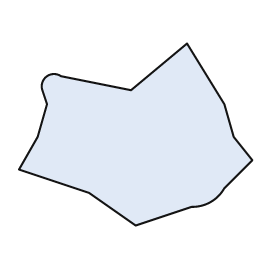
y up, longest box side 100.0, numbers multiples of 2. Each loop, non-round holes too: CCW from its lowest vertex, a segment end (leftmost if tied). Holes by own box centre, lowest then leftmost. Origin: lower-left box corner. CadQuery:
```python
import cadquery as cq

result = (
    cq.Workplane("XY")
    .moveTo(50.0, 0.0)
    .lineTo(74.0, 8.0)
    .threePointArc((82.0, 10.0), (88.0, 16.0))
    .lineTo(100.0, 28.0)
    .lineTo(92.0, 38.0)
    .lineTo(88.0, 52.0)
    .lineTo(72.0, 78.0)
    .lineTo(48.0, 58.0)
    .lineTo(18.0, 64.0)
    .threePointArc((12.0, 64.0), (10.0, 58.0))
    .lineTo(12.0, 52.0)
    .lineTo(8.0, 38.0)
    .lineTo(0.0, 24.0)
    .lineTo(30.0, 14.0)
    .close()
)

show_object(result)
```